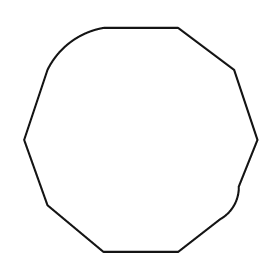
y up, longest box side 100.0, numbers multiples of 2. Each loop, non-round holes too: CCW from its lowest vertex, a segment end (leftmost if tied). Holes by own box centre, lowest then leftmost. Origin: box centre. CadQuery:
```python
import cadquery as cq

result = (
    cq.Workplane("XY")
    .moveTo(-16.0, -48.0)
    .lineTo(16.0, -48.0)
    .lineTo(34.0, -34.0)
    .threePointArc((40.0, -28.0), (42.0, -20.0))
    .lineTo(50.0, 0.0)
    .lineTo(40.0, 30.0)
    .lineTo(16.0, 48.0)
    .lineTo(-16.0, 48.0)
    .threePointArc((-30.0, 42.0), (-40.0, 30.0))
    .lineTo(-50.0, 0.0)
    .lineTo(-40.0, -28.0)
    .close()
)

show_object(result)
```